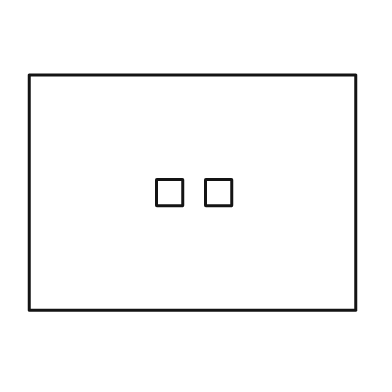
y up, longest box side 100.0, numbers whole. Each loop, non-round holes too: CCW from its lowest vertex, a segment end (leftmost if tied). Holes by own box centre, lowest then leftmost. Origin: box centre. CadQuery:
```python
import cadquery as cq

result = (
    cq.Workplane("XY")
    .moveTo(-50.0, -36.0)
    .lineTo(50.0, -36.0)
    .lineTo(50.0, 36.0)
    .lineTo(-50.0, 36.0)
    .close()
    .moveTo(-11.0, -4.0)
    .lineTo(-3.0, -4.0)
    .lineTo(-3.0, 4.0)
    .lineTo(-11.0, 4.0)
    .close()
    .moveTo(4.0, -4.0)
    .lineTo(12.0, -4.0)
    .lineTo(12.0, 4.0)
    .lineTo(4.0, 4.0)
    .close()
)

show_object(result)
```